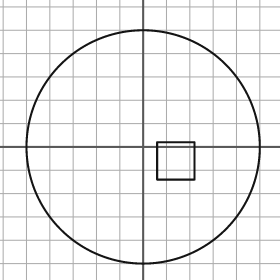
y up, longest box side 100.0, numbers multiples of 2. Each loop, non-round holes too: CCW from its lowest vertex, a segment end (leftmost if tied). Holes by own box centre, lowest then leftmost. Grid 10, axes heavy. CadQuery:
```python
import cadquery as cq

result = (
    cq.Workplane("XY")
    .moveTo(0.0, 0.0)
    .circle(50.0)
    .moveTo(6.0, -14.0)
    .lineTo(22.0, -14.0)
    .lineTo(22.0, 2.0)
    .lineTo(6.0, 2.0)
    .close()
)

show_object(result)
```